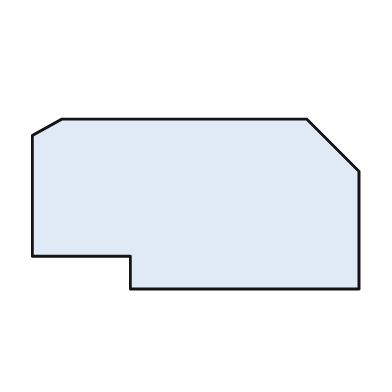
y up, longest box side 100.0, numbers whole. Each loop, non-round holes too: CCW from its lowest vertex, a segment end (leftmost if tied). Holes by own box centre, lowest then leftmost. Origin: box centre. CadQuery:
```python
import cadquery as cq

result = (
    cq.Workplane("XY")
    .moveTo(-20.0, -26.0)
    .lineTo(50.0, -26.0)
    .lineTo(50.0, 10.0)
    .lineTo(34.0, 26.0)
    .lineTo(-41.0, 26.0)
    .lineTo(-50.0, 21.0)
    .lineTo(-50.0, -16.0)
    .lineTo(-20.0, -16.0)
    .close()
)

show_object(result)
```